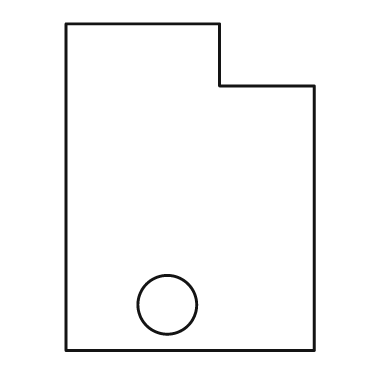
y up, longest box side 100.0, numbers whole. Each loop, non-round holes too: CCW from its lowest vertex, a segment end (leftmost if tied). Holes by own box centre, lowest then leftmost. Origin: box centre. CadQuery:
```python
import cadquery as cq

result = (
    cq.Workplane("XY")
    .moveTo(-38.0, -50.0)
    .lineTo(38.0, -50.0)
    .lineTo(38.0, 31.0)
    .lineTo(9.0, 31.0)
    .lineTo(9.0, 50.0)
    .lineTo(-38.0, 50.0)
    .close()
    .moveTo(-7.0, -36.0)
    .circle(9.0)
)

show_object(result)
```